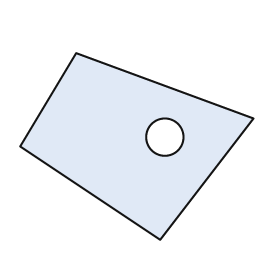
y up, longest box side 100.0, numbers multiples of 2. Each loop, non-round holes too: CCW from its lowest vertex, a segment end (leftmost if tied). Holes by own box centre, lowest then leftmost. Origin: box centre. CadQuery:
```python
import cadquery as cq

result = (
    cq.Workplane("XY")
    .moveTo(10.0, -40.0)
    .lineTo(50.0, 12.0)
    .lineTo(-26.0, 40.0)
    .lineTo(-50.0, 0.0)
    .close()
    .moveTo(12.0, 4.0)
    .circle(8.0)
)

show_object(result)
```